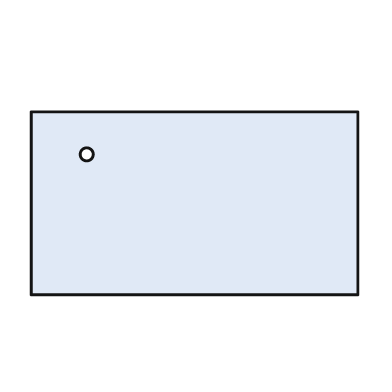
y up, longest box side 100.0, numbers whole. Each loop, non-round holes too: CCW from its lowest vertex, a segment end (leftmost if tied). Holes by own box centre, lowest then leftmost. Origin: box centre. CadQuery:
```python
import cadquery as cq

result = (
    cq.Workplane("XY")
    .moveTo(-50.0, -28.0)
    .lineTo(50.0, -28.0)
    .lineTo(50.0, 28.0)
    .lineTo(-50.0, 28.0)
    .close()
    .moveTo(-33.0, 15.0)
    .circle(2.0)
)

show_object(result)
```